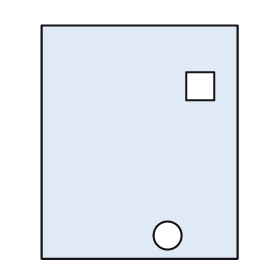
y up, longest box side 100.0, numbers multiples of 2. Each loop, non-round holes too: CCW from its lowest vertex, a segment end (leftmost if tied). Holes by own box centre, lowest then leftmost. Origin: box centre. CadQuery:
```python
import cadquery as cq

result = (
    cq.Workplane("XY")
    .moveTo(-42.0, -50.0)
    .lineTo(42.0, -50.0)
    .lineTo(42.0, 50.0)
    .lineTo(-42.0, 50.0)
    .close()
    .moveTo(12.0, -40.0)
    .circle(6.0)
    .moveTo(20.0, 18.0)
    .lineTo(32.0, 18.0)
    .lineTo(32.0, 30.0)
    .lineTo(20.0, 30.0)
    .close()
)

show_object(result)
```